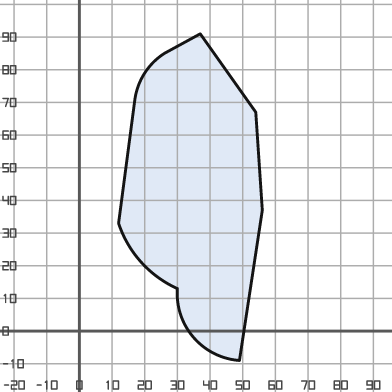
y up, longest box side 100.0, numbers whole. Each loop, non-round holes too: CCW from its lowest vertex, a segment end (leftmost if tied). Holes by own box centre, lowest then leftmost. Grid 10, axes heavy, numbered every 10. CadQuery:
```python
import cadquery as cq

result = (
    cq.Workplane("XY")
    .moveTo(49.0, -9.0)
    .lineTo(56.0, 37.0)
    .lineTo(54.0, 67.0)
    .lineTo(37.0, 91.0)
    .lineTo(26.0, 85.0)
    .threePointArc((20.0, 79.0), (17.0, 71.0))
    .lineTo(12.0, 33.0)
    .threePointArc((19.0, 21.0), (30.0, 13.0))
    .threePointArc((35.0, -2.0), (49.0, -9.0))
    .close()
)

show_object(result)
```